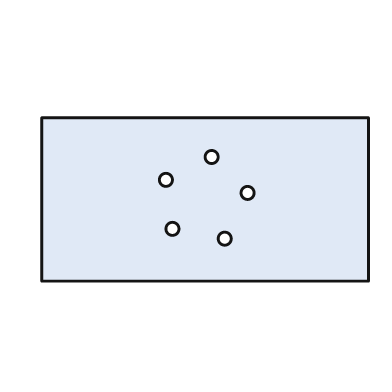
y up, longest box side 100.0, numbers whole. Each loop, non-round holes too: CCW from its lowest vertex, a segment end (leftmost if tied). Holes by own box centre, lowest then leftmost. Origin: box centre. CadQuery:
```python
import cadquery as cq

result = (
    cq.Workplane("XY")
    .moveTo(-50.0, -25.0)
    .lineTo(50.0, -25.0)
    .lineTo(50.0, 25.0)
    .lineTo(-50.0, 25.0)
    .close()
    .moveTo(6.0, -12.0)
    .circle(2.0)
    .moveTo(-10.0, -9.0)
    .circle(2.0)
    .moveTo(13.0, 2.0)
    .circle(2.0)
    .moveTo(-12.0, 6.0)
    .circle(2.0)
    .moveTo(2.0, 13.0)
    .circle(2.0)
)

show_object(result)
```